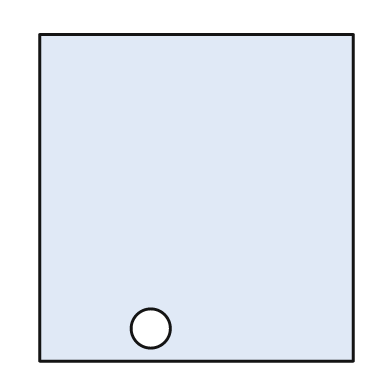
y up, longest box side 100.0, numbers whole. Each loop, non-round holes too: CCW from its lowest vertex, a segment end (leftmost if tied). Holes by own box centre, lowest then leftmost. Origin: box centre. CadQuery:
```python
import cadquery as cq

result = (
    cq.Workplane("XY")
    .moveTo(-48.0, -50.0)
    .lineTo(48.0, -50.0)
    .lineTo(48.0, 50.0)
    .lineTo(-48.0, 50.0)
    .close()
    .moveTo(-14.0, -40.0)
    .circle(6.0)
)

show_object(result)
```